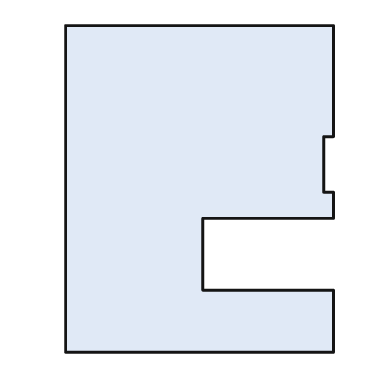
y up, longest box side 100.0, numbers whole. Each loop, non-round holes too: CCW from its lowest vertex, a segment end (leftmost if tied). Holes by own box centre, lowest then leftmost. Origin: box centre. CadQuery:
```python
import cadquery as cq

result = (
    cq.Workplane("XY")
    .moveTo(-41.0, -50.0)
    .lineTo(41.0, -50.0)
    .lineTo(41.0, -31.0)
    .lineTo(1.0, -31.0)
    .lineTo(1.0, -9.0)
    .lineTo(41.0, -9.0)
    .lineTo(41.0, -1.0)
    .lineTo(38.0, -1.0)
    .lineTo(38.0, 16.0)
    .lineTo(41.0, 16.0)
    .lineTo(41.0, 50.0)
    .lineTo(-41.0, 50.0)
    .close()
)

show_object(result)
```